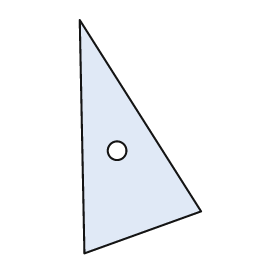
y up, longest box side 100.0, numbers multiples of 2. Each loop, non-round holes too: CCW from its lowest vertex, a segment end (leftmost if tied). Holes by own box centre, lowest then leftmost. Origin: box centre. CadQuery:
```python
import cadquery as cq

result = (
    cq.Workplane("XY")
    .moveTo(-24.0, -50.0)
    .lineTo(26.0, -32.0)
    .lineTo(-26.0, 50.0)
    .close()
    .moveTo(-10.0, -6.0)
    .circle(4.0)
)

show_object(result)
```